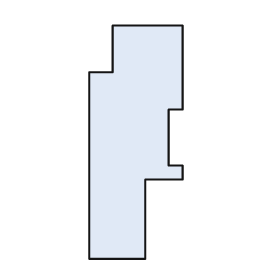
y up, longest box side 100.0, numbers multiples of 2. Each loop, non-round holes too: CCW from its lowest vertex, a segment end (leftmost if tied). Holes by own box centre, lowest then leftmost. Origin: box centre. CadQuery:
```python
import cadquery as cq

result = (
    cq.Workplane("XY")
    .moveTo(-20.0, -50.0)
    .lineTo(4.0, -50.0)
    .lineTo(4.0, -16.0)
    .lineTo(20.0, -16.0)
    .lineTo(20.0, -10.0)
    .lineTo(14.0, -10.0)
    .lineTo(14.0, 14.0)
    .lineTo(20.0, 14.0)
    .lineTo(20.0, 50.0)
    .lineTo(-10.0, 50.0)
    .lineTo(-10.0, 30.0)
    .lineTo(-20.0, 30.0)
    .close()
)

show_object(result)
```